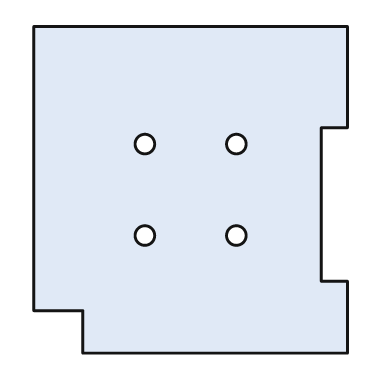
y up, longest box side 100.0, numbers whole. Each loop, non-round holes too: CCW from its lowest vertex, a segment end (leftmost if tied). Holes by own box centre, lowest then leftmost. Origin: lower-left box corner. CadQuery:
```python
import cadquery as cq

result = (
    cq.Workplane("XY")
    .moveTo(15.0, 0.0)
    .lineTo(96.0, 0.0)
    .lineTo(96.0, 22.0)
    .lineTo(88.0, 22.0)
    .lineTo(88.0, 69.0)
    .lineTo(96.0, 69.0)
    .lineTo(96.0, 100.0)
    .lineTo(0.0, 100.0)
    .lineTo(0.0, 13.0)
    .lineTo(15.0, 13.0)
    .close()
    .moveTo(34.0, 36.0)
    .circle(3.0)
    .moveTo(62.0, 36.0)
    .circle(3.0)
    .moveTo(34.0, 64.0)
    .circle(3.0)
    .moveTo(62.0, 64.0)
    .circle(3.0)
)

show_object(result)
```